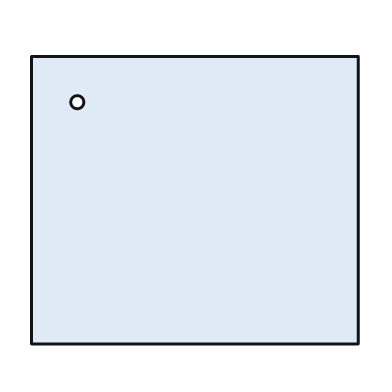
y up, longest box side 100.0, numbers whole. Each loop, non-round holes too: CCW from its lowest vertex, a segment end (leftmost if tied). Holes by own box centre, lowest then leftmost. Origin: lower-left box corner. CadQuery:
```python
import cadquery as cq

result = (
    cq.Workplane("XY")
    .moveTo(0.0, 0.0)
    .lineTo(100.0, 0.0)
    .lineTo(100.0, 88.0)
    .lineTo(0.0, 88.0)
    .close()
    .moveTo(14.0, 74.0)
    .circle(2.0)
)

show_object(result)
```